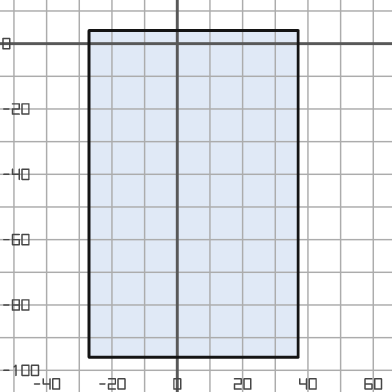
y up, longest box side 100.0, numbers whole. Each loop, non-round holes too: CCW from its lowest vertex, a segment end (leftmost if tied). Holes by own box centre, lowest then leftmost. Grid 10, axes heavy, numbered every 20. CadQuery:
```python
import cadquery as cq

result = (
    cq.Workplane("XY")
    .moveTo(-27.0, -96.0)
    .lineTo(37.0, -96.0)
    .lineTo(37.0, 4.0)
    .lineTo(-27.0, 4.0)
    .close()
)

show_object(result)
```